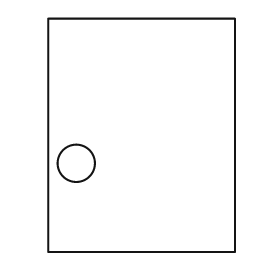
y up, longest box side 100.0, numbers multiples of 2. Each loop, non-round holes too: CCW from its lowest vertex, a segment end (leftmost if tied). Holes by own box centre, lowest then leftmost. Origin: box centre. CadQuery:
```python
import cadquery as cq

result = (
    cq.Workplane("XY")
    .moveTo(-40.0, -50.0)
    .lineTo(40.0, -50.0)
    .lineTo(40.0, 50.0)
    .lineTo(-40.0, 50.0)
    .close()
    .moveTo(-28.0, -12.0)
    .circle(8.0)
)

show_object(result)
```